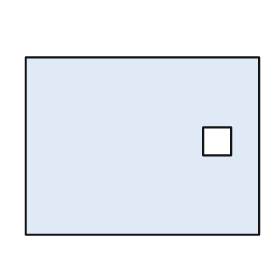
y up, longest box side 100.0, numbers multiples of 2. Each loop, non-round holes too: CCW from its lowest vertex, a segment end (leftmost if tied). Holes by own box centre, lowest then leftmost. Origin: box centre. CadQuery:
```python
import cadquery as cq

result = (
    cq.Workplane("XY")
    .moveTo(-50.0, -38.0)
    .lineTo(50.0, -38.0)
    .lineTo(50.0, 38.0)
    .lineTo(-50.0, 38.0)
    .close()
    .moveTo(26.0, -4.0)
    .lineTo(38.0, -4.0)
    .lineTo(38.0, 8.0)
    .lineTo(26.0, 8.0)
    .close()
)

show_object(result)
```